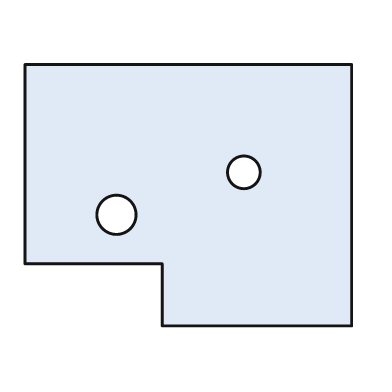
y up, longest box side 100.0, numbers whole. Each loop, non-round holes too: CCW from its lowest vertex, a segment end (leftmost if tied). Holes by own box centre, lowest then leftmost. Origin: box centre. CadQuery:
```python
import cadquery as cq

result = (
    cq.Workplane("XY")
    .moveTo(-8.0, -40.0)
    .lineTo(50.0, -40.0)
    .lineTo(50.0, 40.0)
    .lineTo(-50.0, 40.0)
    .lineTo(-50.0, -21.0)
    .lineTo(-8.0, -21.0)
    .close()
    .moveTo(-22.0, -6.0)
    .circle(6.0)
    .moveTo(17.0, 7.0)
    .circle(5.0)
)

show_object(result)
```